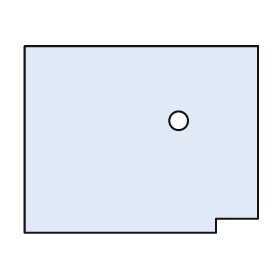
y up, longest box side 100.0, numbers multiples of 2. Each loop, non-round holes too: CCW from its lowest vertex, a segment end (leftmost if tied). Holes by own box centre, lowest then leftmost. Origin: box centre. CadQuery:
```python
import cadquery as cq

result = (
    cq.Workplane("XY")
    .moveTo(-50.0, -40.0)
    .lineTo(32.0, -40.0)
    .lineTo(32.0, -34.0)
    .lineTo(50.0, -34.0)
    .lineTo(50.0, 40.0)
    .lineTo(-50.0, 40.0)
    .close()
    .moveTo(16.0, 8.0)
    .circle(4.0)
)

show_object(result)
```